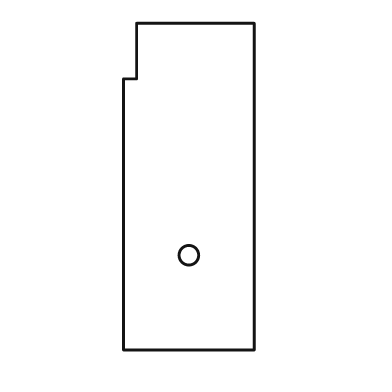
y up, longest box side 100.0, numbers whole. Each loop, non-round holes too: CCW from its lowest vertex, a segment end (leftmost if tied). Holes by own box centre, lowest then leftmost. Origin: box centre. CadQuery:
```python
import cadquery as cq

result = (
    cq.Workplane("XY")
    .moveTo(-20.0, -50.0)
    .lineTo(20.0, -50.0)
    .lineTo(20.0, 50.0)
    .lineTo(-16.0, 50.0)
    .lineTo(-16.0, 33.0)
    .lineTo(-20.0, 33.0)
    .close()
    .moveTo(0.0, -21.0)
    .circle(3.0)
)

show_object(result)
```